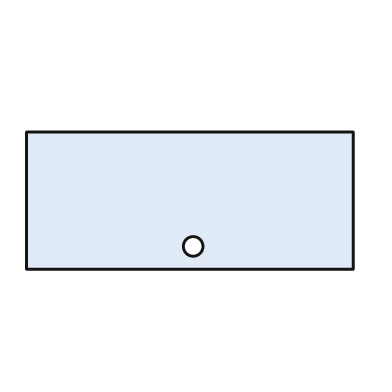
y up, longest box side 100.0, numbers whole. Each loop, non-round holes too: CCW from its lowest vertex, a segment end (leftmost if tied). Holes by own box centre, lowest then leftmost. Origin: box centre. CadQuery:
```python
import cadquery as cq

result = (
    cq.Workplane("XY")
    .moveTo(-50.0, -21.0)
    .lineTo(50.0, -21.0)
    .lineTo(50.0, 21.0)
    .lineTo(-50.0, 21.0)
    .close()
    .moveTo(1.0, -14.0)
    .circle(3.0)
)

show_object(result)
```